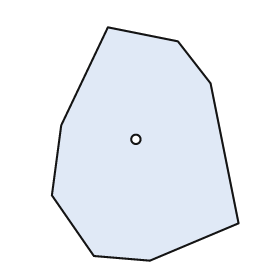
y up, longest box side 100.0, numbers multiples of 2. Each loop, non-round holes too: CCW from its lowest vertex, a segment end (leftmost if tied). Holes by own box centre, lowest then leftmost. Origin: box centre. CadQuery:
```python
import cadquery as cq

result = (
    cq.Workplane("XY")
    .moveTo(2.0, -50.0)
    .lineTo(40.0, -34.0)
    .lineTo(28.0, 26.0)
    .lineTo(14.0, 44.0)
    .lineTo(-16.0, 50.0)
    .lineTo(-36.0, 8.0)
    .lineTo(-40.0, -22.0)
    .lineTo(-22.0, -48.0)
    .close()
    .moveTo(-4.0, 2.0)
    .circle(2.0)
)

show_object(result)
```